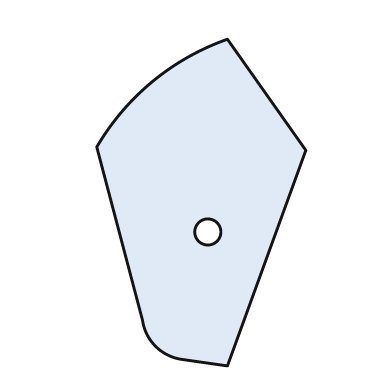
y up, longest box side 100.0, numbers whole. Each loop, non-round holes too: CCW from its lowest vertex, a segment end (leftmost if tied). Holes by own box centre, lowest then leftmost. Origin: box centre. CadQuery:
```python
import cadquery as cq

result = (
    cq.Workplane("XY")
    .moveTo(8.0, -50.0)
    .lineTo(32.0, 16.0)
    .lineTo(8.0, 50.0)
    .threePointArc((-15.0, 37.0), (-32.0, 17.0))
    .lineTo(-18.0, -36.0)
    .threePointArc((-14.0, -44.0), (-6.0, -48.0))
    .close()
    .moveTo(2.0, -9.0)
    .circle(4.0)
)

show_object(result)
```